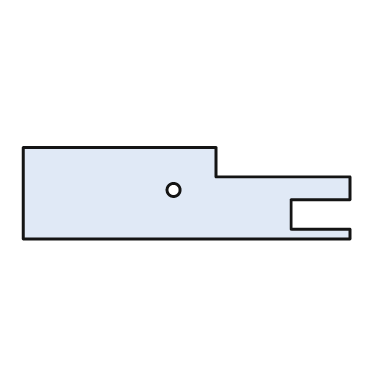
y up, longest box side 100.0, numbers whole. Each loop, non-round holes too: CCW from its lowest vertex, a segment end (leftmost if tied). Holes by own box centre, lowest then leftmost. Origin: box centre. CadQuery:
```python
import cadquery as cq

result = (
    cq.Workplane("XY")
    .moveTo(-50.0, -14.0)
    .lineTo(50.0, -14.0)
    .lineTo(50.0, -11.0)
    .lineTo(32.0, -11.0)
    .lineTo(32.0, -2.0)
    .lineTo(50.0, -2.0)
    .lineTo(50.0, 5.0)
    .lineTo(9.0, 5.0)
    .lineTo(9.0, 14.0)
    .lineTo(-50.0, 14.0)
    .close()
    .moveTo(-4.0, 1.0)
    .circle(2.0)
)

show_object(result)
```